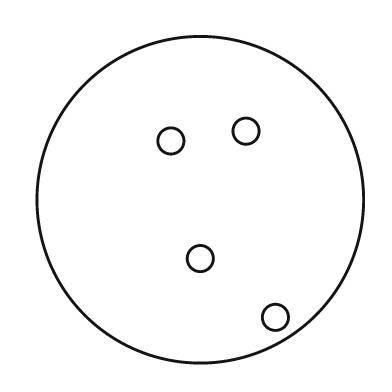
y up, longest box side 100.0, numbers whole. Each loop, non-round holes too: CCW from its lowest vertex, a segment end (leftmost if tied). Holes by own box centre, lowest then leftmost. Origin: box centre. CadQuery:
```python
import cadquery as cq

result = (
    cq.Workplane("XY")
    .moveTo(0.0, 0.0)
    .circle(50.0)
    .moveTo(23.0, -36.0)
    .circle(4.0)
    .moveTo(0.0, -18.0)
    .circle(4.0)
    .moveTo(-9.0, 18.0)
    .circle(4.0)
    .moveTo(14.0, 21.0)
    .circle(4.0)
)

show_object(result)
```